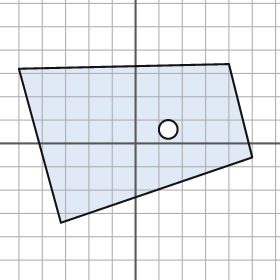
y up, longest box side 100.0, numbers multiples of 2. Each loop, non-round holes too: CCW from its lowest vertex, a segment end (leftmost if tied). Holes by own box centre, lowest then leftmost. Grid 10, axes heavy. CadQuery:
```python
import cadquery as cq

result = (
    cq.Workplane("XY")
    .moveTo(-32.0, -34.0)
    .lineTo(50.0, -6.0)
    .lineTo(40.0, 34.0)
    .lineTo(-50.0, 32.0)
    .close()
    .moveTo(14.0, 6.0)
    .circle(4.0)
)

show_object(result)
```